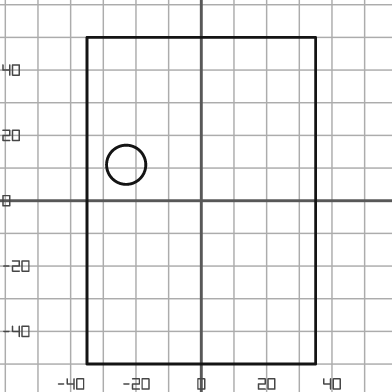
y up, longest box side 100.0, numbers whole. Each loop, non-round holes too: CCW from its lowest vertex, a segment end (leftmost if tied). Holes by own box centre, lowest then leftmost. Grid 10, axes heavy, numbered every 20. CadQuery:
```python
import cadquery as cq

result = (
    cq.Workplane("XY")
    .moveTo(-35.0, -50.0)
    .lineTo(35.0, -50.0)
    .lineTo(35.0, 50.0)
    .lineTo(-35.0, 50.0)
    .close()
    .moveTo(-23.0, 11.0)
    .circle(6.0)
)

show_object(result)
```